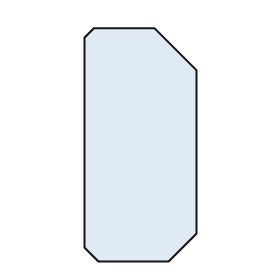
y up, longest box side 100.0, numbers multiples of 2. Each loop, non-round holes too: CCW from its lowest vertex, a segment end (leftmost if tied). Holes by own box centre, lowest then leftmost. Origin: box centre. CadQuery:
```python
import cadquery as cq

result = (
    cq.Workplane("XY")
    .moveTo(-18.0, -50.0)
    .lineTo(12.0, -50.0)
    .lineTo(24.0, -38.0)
    .lineTo(24.0, 32.0)
    .lineTo(6.0, 50.0)
    .lineTo(-20.0, 50.0)
    .lineTo(-24.0, 46.0)
    .lineTo(-24.0, -44.0)
    .close()
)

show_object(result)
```